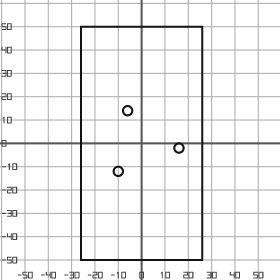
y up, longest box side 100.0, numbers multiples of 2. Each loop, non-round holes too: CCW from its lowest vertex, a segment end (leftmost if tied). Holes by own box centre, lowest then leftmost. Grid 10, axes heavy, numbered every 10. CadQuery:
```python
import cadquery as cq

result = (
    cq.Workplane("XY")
    .moveTo(-26.0, -50.0)
    .lineTo(26.0, -50.0)
    .lineTo(26.0, 50.0)
    .lineTo(-26.0, 50.0)
    .close()
    .moveTo(-10.0, -12.0)
    .circle(2.0)
    .moveTo(16.0, -2.0)
    .circle(2.0)
    .moveTo(-6.0, 14.0)
    .circle(2.0)
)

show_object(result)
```